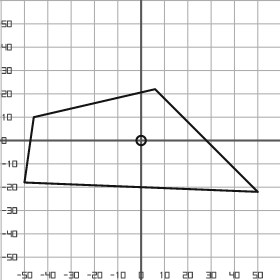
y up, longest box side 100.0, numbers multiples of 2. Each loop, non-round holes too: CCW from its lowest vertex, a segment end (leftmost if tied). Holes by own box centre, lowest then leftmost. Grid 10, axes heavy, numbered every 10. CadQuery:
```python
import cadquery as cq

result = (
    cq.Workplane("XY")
    .moveTo(50.0, -22.0)
    .lineTo(6.0, 22.0)
    .lineTo(-46.0, 10.0)
    .lineTo(-50.0, -18.0)
    .close()
    .moveTo(0.0, 0.0)
    .circle(2.0)
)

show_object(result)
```